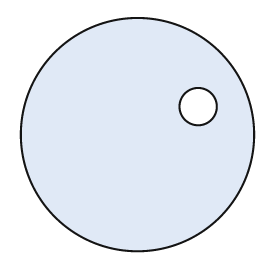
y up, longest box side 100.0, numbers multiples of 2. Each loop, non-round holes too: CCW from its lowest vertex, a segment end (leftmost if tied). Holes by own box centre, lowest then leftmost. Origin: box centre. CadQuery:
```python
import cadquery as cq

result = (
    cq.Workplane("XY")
    .moveTo(0.0, 0.0)
    .circle(50.0)
    .moveTo(26.0, 12.0)
    .circle(8.0)
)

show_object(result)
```